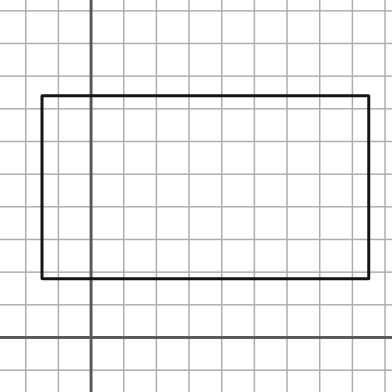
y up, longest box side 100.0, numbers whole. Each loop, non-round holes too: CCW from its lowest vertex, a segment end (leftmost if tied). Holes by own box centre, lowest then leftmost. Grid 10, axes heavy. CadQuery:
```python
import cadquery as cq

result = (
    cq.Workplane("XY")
    .moveTo(-15.0, 18.0)
    .lineTo(85.0, 18.0)
    .lineTo(85.0, 74.0)
    .lineTo(-15.0, 74.0)
    .close()
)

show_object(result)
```